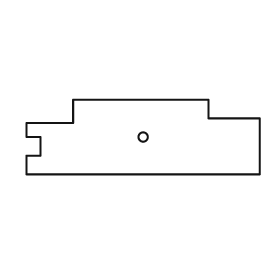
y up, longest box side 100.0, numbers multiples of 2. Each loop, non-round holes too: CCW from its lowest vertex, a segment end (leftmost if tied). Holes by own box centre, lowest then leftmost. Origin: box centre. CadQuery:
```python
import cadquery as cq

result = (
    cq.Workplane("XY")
    .moveTo(-50.0, -16.0)
    .lineTo(50.0, -16.0)
    .lineTo(50.0, 8.0)
    .lineTo(28.0, 8.0)
    .lineTo(28.0, 16.0)
    .lineTo(-30.0, 16.0)
    .lineTo(-30.0, 6.0)
    .lineTo(-50.0, 6.0)
    .lineTo(-50.0, 0.0)
    .lineTo(-44.0, 0.0)
    .lineTo(-44.0, -8.0)
    .lineTo(-50.0, -8.0)
    .close()
    .moveTo(0.0, 0.0)
    .circle(2.0)
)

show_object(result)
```